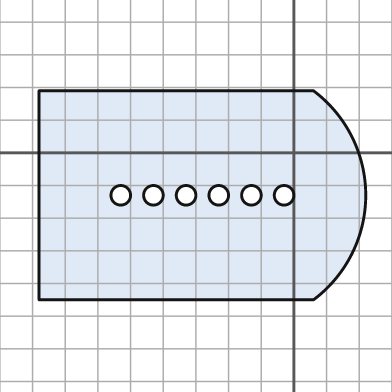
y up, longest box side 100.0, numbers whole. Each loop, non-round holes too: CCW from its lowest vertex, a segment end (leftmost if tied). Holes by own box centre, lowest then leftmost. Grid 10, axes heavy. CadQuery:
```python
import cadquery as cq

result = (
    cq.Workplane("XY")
    .moveTo(-78.0, -45.0)
    .lineTo(6.0, -45.0)
    .threePointArc((22.0, -13.0), (6.0, 19.0))
    .lineTo(-78.0, 19.0)
    .close()
    .moveTo(-53.0, -13.0)
    .circle(3.0)
    .moveTo(-43.0, -13.0)
    .circle(3.0)
    .moveTo(-33.0, -13.0)
    .circle(3.0)
    .moveTo(-23.0, -13.0)
    .circle(3.0)
    .moveTo(-13.0, -13.0)
    .circle(3.0)
    .moveTo(-3.0, -13.0)
    .circle(3.0)
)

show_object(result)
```